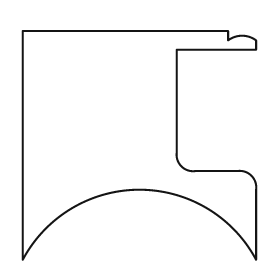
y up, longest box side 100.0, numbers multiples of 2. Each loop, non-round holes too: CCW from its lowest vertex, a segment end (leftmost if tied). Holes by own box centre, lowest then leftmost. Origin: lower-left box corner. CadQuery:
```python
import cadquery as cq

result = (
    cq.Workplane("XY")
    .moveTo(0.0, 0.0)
    .threePointArc((50.0, 30.0), (100.0, 0.0))
    .lineTo(100.0, 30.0)
    .threePointArc((98.0, 36.0), (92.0, 38.0))
    .lineTo(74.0, 38.0)
    .threePointArc((68.0, 40.0), (66.0, 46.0))
    .lineTo(66.0, 90.0)
    .lineTo(100.0, 90.0)
    .lineTo(100.0, 94.0)
    .threePointArc((94.0, 96.0), (88.0, 94.0))
    .lineTo(88.0, 98.0)
    .lineTo(0.0, 98.0)
    .close()
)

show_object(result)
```